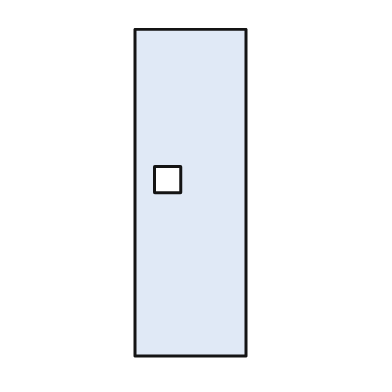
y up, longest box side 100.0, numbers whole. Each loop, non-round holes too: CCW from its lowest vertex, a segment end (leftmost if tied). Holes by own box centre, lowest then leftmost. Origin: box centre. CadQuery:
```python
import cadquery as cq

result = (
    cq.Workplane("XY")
    .moveTo(-17.0, -50.0)
    .lineTo(17.0, -50.0)
    .lineTo(17.0, 50.0)
    .lineTo(-17.0, 50.0)
    .close()
    .moveTo(-11.0, 0.0)
    .lineTo(-3.0, 0.0)
    .lineTo(-3.0, 8.0)
    .lineTo(-11.0, 8.0)
    .close()
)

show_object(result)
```